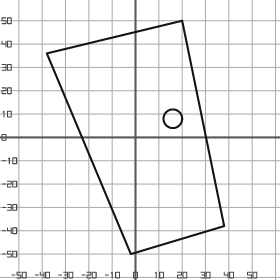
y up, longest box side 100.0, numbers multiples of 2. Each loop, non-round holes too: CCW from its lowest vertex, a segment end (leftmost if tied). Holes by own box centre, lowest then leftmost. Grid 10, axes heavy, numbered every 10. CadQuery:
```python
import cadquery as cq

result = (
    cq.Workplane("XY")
    .moveTo(-2.0, -50.0)
    .lineTo(38.0, -38.0)
    .lineTo(20.0, 50.0)
    .lineTo(-38.0, 36.0)
    .close()
    .moveTo(16.0, 8.0)
    .circle(4.0)
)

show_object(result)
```